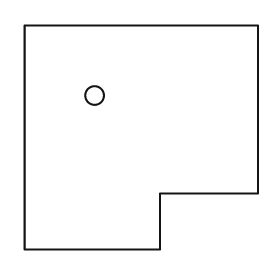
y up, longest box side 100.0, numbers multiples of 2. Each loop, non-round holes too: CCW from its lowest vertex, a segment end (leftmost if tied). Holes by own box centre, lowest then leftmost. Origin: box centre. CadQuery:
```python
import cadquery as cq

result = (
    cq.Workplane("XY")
    .moveTo(-50.0, -48.0)
    .lineTo(8.0, -48.0)
    .lineTo(8.0, -24.0)
    .lineTo(50.0, -24.0)
    .lineTo(50.0, 48.0)
    .lineTo(-50.0, 48.0)
    .close()
    .moveTo(-20.0, 18.0)
    .circle(4.0)
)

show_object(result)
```